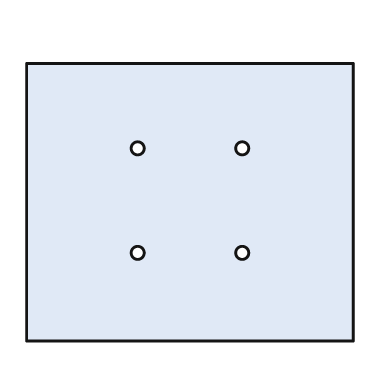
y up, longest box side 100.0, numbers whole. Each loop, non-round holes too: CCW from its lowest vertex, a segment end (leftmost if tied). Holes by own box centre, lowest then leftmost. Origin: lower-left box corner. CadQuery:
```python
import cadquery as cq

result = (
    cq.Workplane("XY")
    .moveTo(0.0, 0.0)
    .lineTo(100.0, 0.0)
    .lineTo(100.0, 85.0)
    .lineTo(0.0, 85.0)
    .close()
    .moveTo(34.0, 27.0)
    .circle(2.0)
    .moveTo(66.0, 27.0)
    .circle(2.0)
    .moveTo(34.0, 59.0)
    .circle(2.0)
    .moveTo(66.0, 59.0)
    .circle(2.0)
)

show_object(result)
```